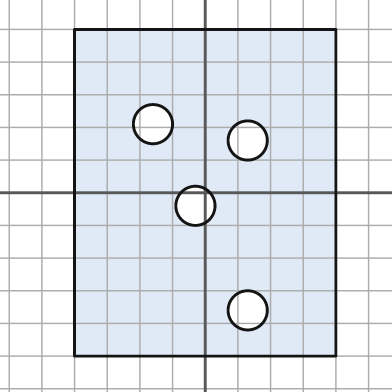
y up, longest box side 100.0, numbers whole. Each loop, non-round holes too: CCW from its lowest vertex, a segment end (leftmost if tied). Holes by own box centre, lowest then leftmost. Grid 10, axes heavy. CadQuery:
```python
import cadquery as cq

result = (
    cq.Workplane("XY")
    .moveTo(-40.0, -50.0)
    .lineTo(40.0, -50.0)
    .lineTo(40.0, 50.0)
    .lineTo(-40.0, 50.0)
    .close()
    .moveTo(13.0, -36.0)
    .circle(6.0)
    .moveTo(-3.0, -4.0)
    .circle(6.0)
    .moveTo(13.0, 16.0)
    .circle(6.0)
    .moveTo(-16.0, 21.0)
    .circle(6.0)
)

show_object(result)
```